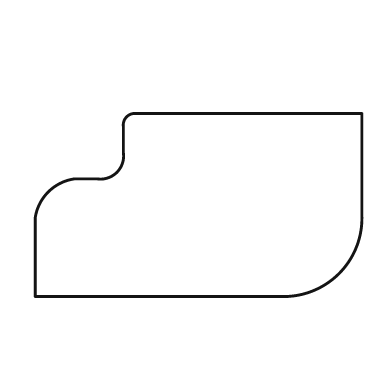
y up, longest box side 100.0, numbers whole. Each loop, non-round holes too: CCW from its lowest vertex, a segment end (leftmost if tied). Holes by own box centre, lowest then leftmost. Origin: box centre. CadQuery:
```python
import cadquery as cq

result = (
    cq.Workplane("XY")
    .moveTo(-50.0, -28.0)
    .lineTo(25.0, -28.0)
    .threePointArc((43.0, -21.0), (50.0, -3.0))
    .lineTo(50.0, 28.0)
    .lineTo(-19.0, 28.0)
    .threePointArc((-22.0, 27.0), (-23.0, 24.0))
    .lineTo(-23.0, 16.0)
    .threePointArc((-25.0, 10.0), (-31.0, 8.0))
    .lineTo(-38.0, 8.0)
    .threePointArc((-46.0, 4.0), (-50.0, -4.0))
    .close()
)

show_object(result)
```